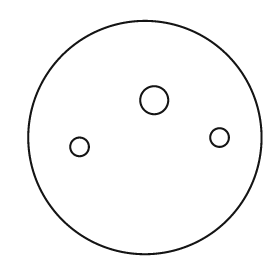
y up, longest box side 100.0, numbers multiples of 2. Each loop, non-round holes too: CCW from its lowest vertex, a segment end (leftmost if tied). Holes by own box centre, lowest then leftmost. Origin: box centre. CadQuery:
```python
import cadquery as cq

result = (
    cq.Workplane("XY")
    .moveTo(0.0, 0.0)
    .circle(50.0)
    .moveTo(-28.0, -4.0)
    .circle(4.0)
    .moveTo(32.0, 0.0)
    .circle(4.0)
    .moveTo(4.0, 16.0)
    .circle(6.0)
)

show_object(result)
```